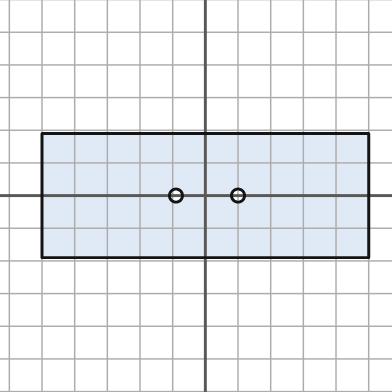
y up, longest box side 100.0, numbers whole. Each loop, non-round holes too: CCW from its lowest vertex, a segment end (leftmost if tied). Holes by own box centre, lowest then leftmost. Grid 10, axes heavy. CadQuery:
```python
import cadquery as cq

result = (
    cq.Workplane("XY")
    .moveTo(-50.0, -19.0)
    .lineTo(50.0, -19.0)
    .lineTo(50.0, 19.0)
    .lineTo(-50.0, 19.0)
    .close()
    .moveTo(-9.0, 0.0)
    .circle(2.0)
    .moveTo(10.0, 0.0)
    .circle(2.0)
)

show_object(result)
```